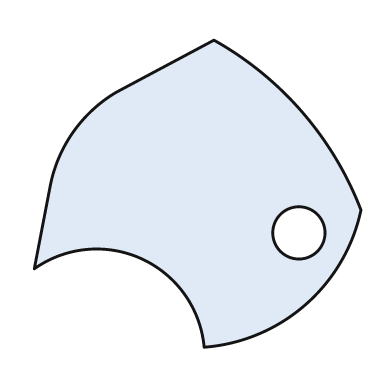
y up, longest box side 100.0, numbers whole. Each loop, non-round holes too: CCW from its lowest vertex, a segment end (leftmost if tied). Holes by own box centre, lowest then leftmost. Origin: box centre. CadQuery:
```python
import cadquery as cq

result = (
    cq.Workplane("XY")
    .moveTo(2.0, -47.0)
    .threePointArc((33.0, -34.0), (50.0, -5.0))
    .threePointArc((32.0, 25.0), (5.0, 47.0))
    .lineTo(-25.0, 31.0)
    .threePointArc((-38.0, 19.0), (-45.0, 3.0))
    .lineTo(-50.0, -23.0)
    .threePointArc((-17.0, -20.0), (2.0, -47.0))
    .close()
    .moveTo(31.0, -12.0)
    .circle(8.0)
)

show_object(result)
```